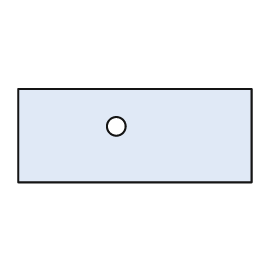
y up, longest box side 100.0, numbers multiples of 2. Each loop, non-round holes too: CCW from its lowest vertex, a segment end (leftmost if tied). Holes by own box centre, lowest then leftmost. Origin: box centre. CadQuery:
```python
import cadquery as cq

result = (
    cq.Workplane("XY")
    .moveTo(-50.0, -20.0)
    .lineTo(50.0, -20.0)
    .lineTo(50.0, 20.0)
    .lineTo(-50.0, 20.0)
    .close()
    .moveTo(-8.0, 4.0)
    .circle(4.0)
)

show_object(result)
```